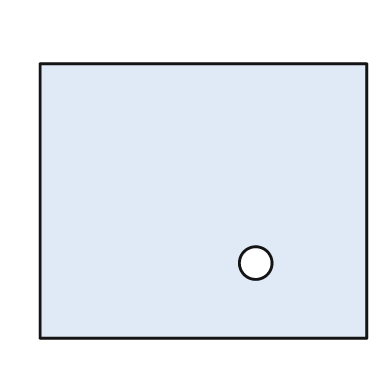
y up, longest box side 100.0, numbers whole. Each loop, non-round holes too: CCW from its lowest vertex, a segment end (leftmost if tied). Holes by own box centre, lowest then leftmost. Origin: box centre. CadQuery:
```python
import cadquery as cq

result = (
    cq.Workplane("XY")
    .moveTo(-50.0, -42.0)
    .lineTo(50.0, -42.0)
    .lineTo(50.0, 42.0)
    .lineTo(-50.0, 42.0)
    .close()
    .moveTo(16.0, -19.0)
    .circle(5.0)
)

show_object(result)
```